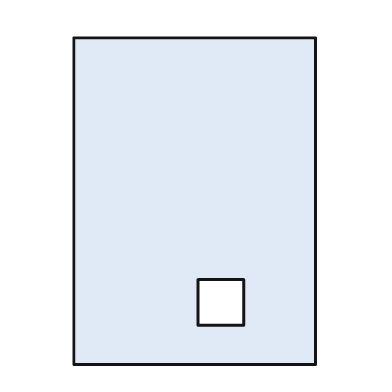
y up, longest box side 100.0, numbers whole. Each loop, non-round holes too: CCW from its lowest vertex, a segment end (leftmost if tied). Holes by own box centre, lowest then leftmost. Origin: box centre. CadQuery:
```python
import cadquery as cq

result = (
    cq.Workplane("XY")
    .moveTo(-37.0, -50.0)
    .lineTo(37.0, -50.0)
    .lineTo(37.0, 50.0)
    .lineTo(-37.0, 50.0)
    .close()
    .moveTo(1.0, -38.0)
    .lineTo(15.0, -38.0)
    .lineTo(15.0, -24.0)
    .lineTo(1.0, -24.0)
    .close()
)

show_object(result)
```